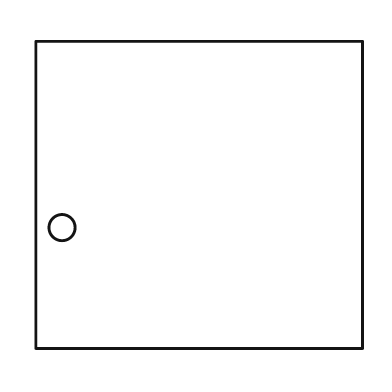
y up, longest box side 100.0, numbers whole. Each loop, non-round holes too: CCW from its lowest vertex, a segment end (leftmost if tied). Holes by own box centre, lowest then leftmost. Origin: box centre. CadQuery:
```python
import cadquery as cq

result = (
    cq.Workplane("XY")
    .moveTo(-50.0, -47.0)
    .lineTo(50.0, -47.0)
    .lineTo(50.0, 47.0)
    .lineTo(-50.0, 47.0)
    .close()
    .moveTo(-42.0, -10.0)
    .circle(4.0)
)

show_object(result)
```